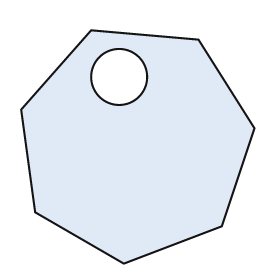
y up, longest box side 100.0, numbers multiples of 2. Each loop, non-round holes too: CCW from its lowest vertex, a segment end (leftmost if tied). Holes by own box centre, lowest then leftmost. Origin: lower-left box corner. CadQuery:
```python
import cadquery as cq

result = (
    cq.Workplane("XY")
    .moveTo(44.0, 0.0)
    .lineTo(86.0, 16.0)
    .lineTo(100.0, 58.0)
    .lineTo(76.0, 96.0)
    .lineTo(30.0, 100.0)
    .lineTo(0.0, 66.0)
    .lineTo(6.0, 22.0)
    .close()
    .moveTo(42.0, 80.0)
    .circle(12.0)
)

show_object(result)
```